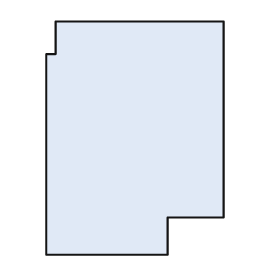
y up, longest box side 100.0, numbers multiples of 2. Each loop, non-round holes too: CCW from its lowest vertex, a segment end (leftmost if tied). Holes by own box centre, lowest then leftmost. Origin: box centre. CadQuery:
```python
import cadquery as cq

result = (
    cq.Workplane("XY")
    .moveTo(-38.0, -50.0)
    .lineTo(14.0, -50.0)
    .lineTo(14.0, -34.0)
    .lineTo(38.0, -34.0)
    .lineTo(38.0, 50.0)
    .lineTo(-34.0, 50.0)
    .lineTo(-34.0, 36.0)
    .lineTo(-38.0, 36.0)
    .close()
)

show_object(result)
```